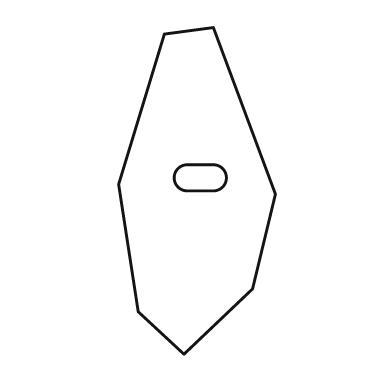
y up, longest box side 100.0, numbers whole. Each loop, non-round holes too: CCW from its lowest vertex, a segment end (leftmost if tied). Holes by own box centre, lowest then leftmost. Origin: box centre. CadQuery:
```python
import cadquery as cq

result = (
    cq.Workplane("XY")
    .moveTo(-4.0, -50.0)
    .lineTo(17.0, -30.0)
    .lineTo(24.0, -1.0)
    .lineTo(5.0, 50.0)
    .lineTo(-10.0, 48.0)
    .lineTo(-24.0, 2.0)
    .lineTo(-18.0, -37.0)
    .close()
    .moveTo(-3.0, 0.0)
    .lineTo(5.0, 0.0)
    .threePointArc((9.0, 4.0), (5.0, 8.0))
    .lineTo(-3.0, 8.0)
    .threePointArc((-7.0, 4.0), (-3.0, 0.0))
    .close()
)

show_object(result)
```